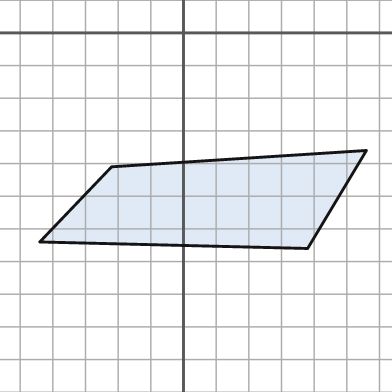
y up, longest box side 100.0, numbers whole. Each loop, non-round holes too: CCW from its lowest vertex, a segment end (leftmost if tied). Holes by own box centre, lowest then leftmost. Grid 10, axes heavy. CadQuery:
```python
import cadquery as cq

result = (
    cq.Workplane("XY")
    .moveTo(38.0, -66.0)
    .lineTo(56.0, -36.0)
    .lineTo(-22.0, -41.0)
    .lineTo(-44.0, -64.0)
    .close()
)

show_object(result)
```